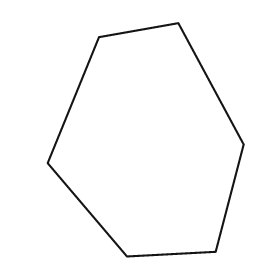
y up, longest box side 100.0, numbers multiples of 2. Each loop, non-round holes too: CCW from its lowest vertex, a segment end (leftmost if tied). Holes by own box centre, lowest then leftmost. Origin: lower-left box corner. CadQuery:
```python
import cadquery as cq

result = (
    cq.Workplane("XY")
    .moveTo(34.0, 0.0)
    .lineTo(72.0, 2.0)
    .lineTo(84.0, 48.0)
    .lineTo(56.0, 100.0)
    .lineTo(22.0, 94.0)
    .lineTo(0.0, 40.0)
    .close()
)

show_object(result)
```